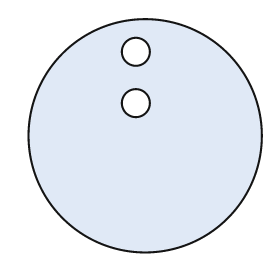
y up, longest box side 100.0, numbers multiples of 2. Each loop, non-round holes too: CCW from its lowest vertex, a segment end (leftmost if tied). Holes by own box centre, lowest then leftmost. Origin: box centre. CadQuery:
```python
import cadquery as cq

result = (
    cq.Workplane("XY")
    .moveTo(0.0, 0.0)
    .circle(50.0)
    .moveTo(-4.0, 14.0)
    .circle(6.0)
    .moveTo(-4.0, 36.0)
    .circle(6.0)
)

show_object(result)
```